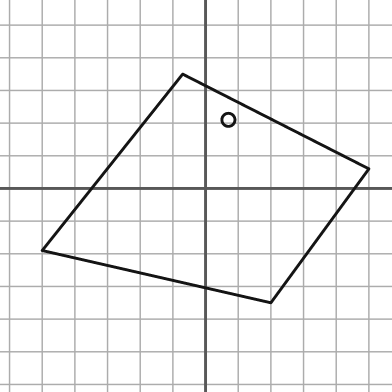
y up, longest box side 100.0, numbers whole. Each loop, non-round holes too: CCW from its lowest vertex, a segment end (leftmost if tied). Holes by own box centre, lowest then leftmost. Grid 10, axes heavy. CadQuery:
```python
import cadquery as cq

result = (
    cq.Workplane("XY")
    .moveTo(20.0, -35.0)
    .lineTo(50.0, 6.0)
    .lineTo(-7.0, 35.0)
    .lineTo(-50.0, -19.0)
    .close()
    .moveTo(7.0, 21.0)
    .circle(2.0)
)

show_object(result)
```